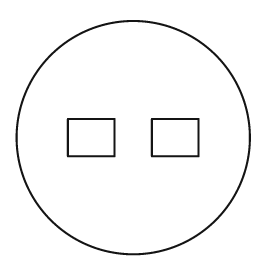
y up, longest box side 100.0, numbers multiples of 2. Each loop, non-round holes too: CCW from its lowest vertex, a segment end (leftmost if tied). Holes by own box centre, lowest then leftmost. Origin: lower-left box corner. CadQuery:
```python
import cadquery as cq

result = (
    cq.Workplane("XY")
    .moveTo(50.0, 50.0)
    .circle(50.0)
    .moveTo(22.0, 42.0)
    .lineTo(42.0, 42.0)
    .lineTo(42.0, 58.0)
    .lineTo(22.0, 58.0)
    .close()
    .moveTo(58.0, 42.0)
    .lineTo(78.0, 42.0)
    .lineTo(78.0, 58.0)
    .lineTo(58.0, 58.0)
    .close()
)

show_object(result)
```